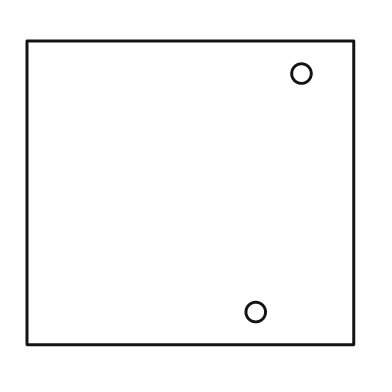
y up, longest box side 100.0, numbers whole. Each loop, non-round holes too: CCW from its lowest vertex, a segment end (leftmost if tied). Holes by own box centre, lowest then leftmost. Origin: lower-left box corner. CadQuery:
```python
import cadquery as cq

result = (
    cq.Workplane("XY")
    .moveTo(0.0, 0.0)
    .lineTo(100.0, 0.0)
    .lineTo(100.0, 93.0)
    .lineTo(0.0, 93.0)
    .close()
    .moveTo(70.0, 10.0)
    .circle(3.0)
    .moveTo(84.0, 83.0)
    .circle(3.0)
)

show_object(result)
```